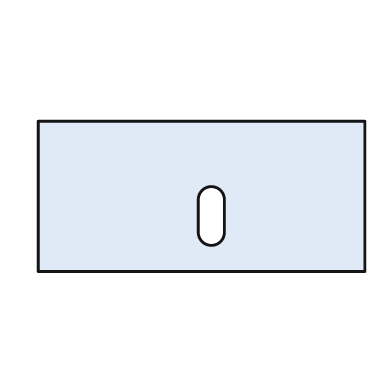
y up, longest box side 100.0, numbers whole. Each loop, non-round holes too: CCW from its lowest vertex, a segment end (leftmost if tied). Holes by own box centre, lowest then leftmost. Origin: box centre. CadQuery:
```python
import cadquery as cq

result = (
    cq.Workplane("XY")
    .moveTo(-50.0, -23.0)
    .lineTo(50.0, -23.0)
    .lineTo(50.0, 23.0)
    .lineTo(-50.0, 23.0)
    .close()
    .moveTo(-1.0, -11.0)
    .threePointArc((3.0, -15.0), (7.0, -11.0))
    .lineTo(7.0, -1.0)
    .threePointArc((3.0, 3.0), (-1.0, -1.0))
    .close()
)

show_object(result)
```